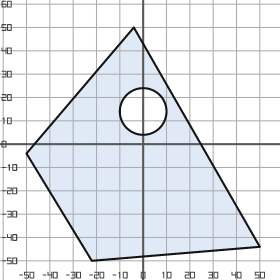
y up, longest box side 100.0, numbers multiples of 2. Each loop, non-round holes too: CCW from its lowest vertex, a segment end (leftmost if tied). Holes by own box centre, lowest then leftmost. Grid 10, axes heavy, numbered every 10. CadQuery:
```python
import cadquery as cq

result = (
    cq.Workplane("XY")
    .moveTo(-22.0, -50.0)
    .lineTo(50.0, -44.0)
    .lineTo(-4.0, 50.0)
    .lineTo(-50.0, -4.0)
    .close()
    .moveTo(0.0, 14.0)
    .circle(10.0)
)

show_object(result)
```